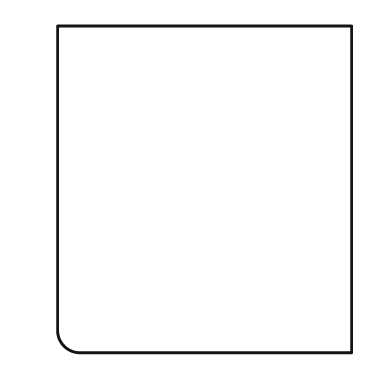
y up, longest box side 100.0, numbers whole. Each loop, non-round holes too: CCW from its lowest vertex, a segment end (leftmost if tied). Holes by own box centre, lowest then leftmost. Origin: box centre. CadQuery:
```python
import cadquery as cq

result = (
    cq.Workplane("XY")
    .moveTo(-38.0, -50.0)
    .lineTo(45.0, -50.0)
    .lineTo(45.0, 50.0)
    .lineTo(-45.0, 50.0)
    .lineTo(-45.0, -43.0)
    .threePointArc((-43.0, -48.0), (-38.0, -50.0))
    .close()
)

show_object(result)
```